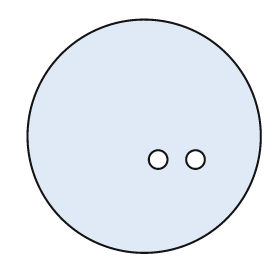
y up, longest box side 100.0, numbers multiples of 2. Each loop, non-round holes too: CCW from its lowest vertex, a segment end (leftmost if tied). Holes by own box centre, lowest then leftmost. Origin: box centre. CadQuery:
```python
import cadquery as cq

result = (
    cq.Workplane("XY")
    .moveTo(0.0, 0.0)
    .circle(50.0)
    .moveTo(6.0, -10.0)
    .circle(4.0)
    .moveTo(22.0, -10.0)
    .circle(4.0)
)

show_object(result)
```